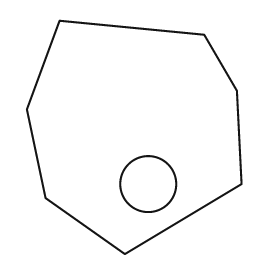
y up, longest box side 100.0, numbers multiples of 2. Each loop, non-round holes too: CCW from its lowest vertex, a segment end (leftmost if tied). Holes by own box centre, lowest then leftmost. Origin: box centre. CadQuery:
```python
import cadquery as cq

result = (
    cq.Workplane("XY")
    .moveTo(-4.0, -50.0)
    .lineTo(46.0, -20.0)
    .lineTo(44.0, 20.0)
    .lineTo(30.0, 44.0)
    .lineTo(-32.0, 50.0)
    .lineTo(-46.0, 12.0)
    .lineTo(-38.0, -26.0)
    .close()
    .moveTo(6.0, -20.0)
    .circle(12.0)
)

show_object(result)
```